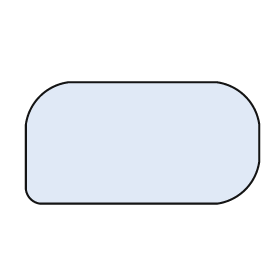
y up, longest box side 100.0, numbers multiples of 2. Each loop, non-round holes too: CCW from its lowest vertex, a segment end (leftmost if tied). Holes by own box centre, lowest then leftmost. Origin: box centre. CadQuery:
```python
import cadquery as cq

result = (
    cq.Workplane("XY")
    .moveTo(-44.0, -26.0)
    .lineTo(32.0, -26.0)
    .threePointArc((44.0, -20.0), (50.0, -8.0))
    .lineTo(50.0, 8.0)
    .threePointArc((44.0, 20.0), (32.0, 26.0))
    .lineTo(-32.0, 26.0)
    .threePointArc((-44.0, 20.0), (-50.0, 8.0))
    .lineTo(-50.0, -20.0)
    .threePointArc((-48.0, -24.0), (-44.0, -26.0))
    .close()
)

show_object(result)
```